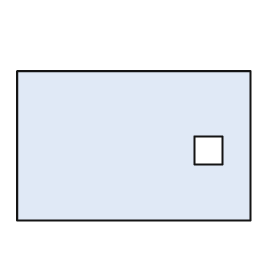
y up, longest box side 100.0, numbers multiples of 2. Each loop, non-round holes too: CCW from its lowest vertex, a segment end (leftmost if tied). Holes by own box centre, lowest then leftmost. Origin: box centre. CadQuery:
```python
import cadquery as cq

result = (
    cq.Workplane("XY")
    .moveTo(-50.0, -32.0)
    .lineTo(50.0, -32.0)
    .lineTo(50.0, 32.0)
    .lineTo(-50.0, 32.0)
    .close()
    .moveTo(26.0, -8.0)
    .lineTo(38.0, -8.0)
    .lineTo(38.0, 4.0)
    .lineTo(26.0, 4.0)
    .close()
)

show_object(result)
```